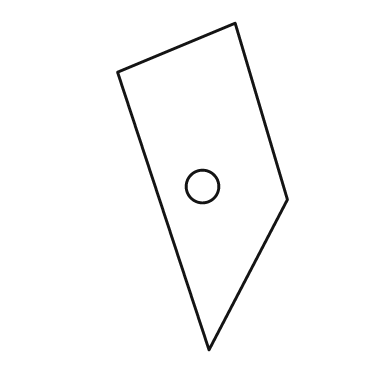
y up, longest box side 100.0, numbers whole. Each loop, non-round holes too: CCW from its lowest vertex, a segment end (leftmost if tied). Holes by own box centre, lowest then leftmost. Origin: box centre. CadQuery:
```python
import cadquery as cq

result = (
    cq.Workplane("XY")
    .moveTo(2.0, -50.0)
    .lineTo(26.0, -4.0)
    .lineTo(10.0, 50.0)
    .lineTo(-26.0, 35.0)
    .close()
    .moveTo(0.0, 0.0)
    .circle(5.0)
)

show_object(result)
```